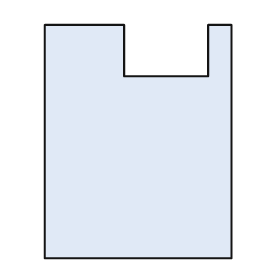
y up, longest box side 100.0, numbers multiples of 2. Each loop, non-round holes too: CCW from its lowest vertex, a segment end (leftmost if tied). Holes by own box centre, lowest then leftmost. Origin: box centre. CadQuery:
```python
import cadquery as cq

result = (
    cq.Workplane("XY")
    .moveTo(-40.0, -50.0)
    .lineTo(40.0, -50.0)
    .lineTo(40.0, 50.0)
    .lineTo(30.0, 50.0)
    .lineTo(30.0, 28.0)
    .lineTo(-6.0, 28.0)
    .lineTo(-6.0, 50.0)
    .lineTo(-40.0, 50.0)
    .close()
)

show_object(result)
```